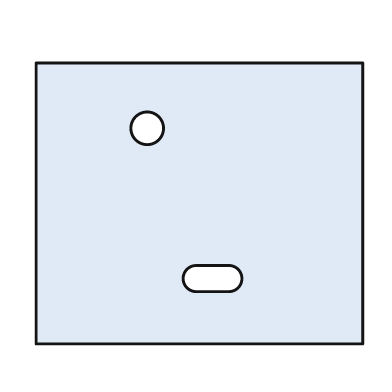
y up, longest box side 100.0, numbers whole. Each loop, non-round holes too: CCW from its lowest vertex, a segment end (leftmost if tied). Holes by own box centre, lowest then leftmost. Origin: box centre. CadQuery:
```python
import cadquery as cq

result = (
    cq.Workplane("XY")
    .moveTo(-50.0, -43.0)
    .lineTo(50.0, -43.0)
    .lineTo(50.0, 43.0)
    .lineTo(-50.0, 43.0)
    .close()
    .moveTo(-1.0, -27.0)
    .lineTo(9.0, -27.0)
    .threePointArc((13.0, -23.0), (9.0, -19.0))
    .lineTo(-1.0, -19.0)
    .threePointArc((-5.0, -23.0), (-1.0, -27.0))
    .close()
    .moveTo(-16.0, 23.0)
    .circle(5.0)
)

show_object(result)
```